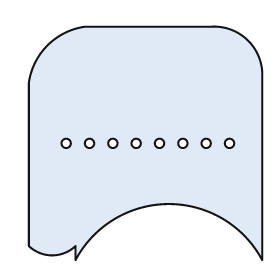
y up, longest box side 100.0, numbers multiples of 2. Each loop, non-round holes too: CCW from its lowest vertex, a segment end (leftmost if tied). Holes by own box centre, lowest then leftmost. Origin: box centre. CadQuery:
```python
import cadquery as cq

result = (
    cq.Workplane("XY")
    .moveTo(-30.0, -50.0)
    .threePointArc((10.0, -26.0), (50.0, -50.0))
    .lineTo(50.0, 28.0)
    .threePointArc((44.0, 44.0), (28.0, 50.0))
    .lineTo(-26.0, 50.0)
    .threePointArc((-42.0, 42.0), (-50.0, 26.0))
    .lineTo(-50.0, -44.0)
    .threePointArc((-40.0, -48.0), (-30.0, -44.0))
    .close()
    .moveTo(-34.0, 0.0)
    .circle(2.0)
    .moveTo(-24.0, 0.0)
    .circle(2.0)
    .moveTo(-14.0, 0.0)
    .circle(2.0)
    .moveTo(-4.0, 0.0)
    .circle(2.0)
    .moveTo(6.0, 0.0)
    .circle(2.0)
    .moveTo(16.0, 0.0)
    .circle(2.0)
    .moveTo(26.0, 0.0)
    .circle(2.0)
    .moveTo(36.0, 0.0)
    .circle(2.0)
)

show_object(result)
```